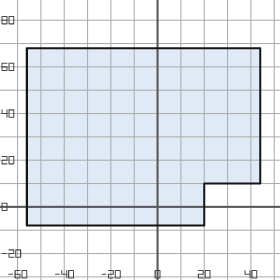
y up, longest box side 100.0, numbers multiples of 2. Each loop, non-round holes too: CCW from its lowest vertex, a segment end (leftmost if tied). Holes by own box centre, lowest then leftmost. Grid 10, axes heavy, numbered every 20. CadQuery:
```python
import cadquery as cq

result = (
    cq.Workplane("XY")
    .moveTo(-56.0, -8.0)
    .lineTo(20.0, -8.0)
    .lineTo(20.0, 10.0)
    .lineTo(44.0, 10.0)
    .lineTo(44.0, 68.0)
    .lineTo(-56.0, 68.0)
    .close()
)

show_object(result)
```